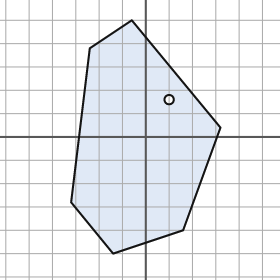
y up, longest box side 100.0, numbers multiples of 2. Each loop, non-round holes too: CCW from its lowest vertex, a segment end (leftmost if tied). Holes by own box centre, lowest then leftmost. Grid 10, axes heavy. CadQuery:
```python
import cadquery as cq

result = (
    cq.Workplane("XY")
    .moveTo(-14.0, -50.0)
    .lineTo(16.0, -40.0)
    .lineTo(32.0, 4.0)
    .lineTo(-6.0, 50.0)
    .lineTo(-24.0, 38.0)
    .lineTo(-32.0, -28.0)
    .close()
    .moveTo(10.0, 16.0)
    .circle(2.0)
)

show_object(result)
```